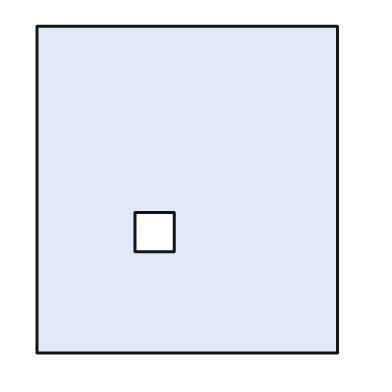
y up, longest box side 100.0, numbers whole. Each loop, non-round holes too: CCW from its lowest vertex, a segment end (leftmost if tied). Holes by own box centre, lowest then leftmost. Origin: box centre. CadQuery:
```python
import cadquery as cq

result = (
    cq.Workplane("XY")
    .moveTo(-46.0, -50.0)
    .lineTo(46.0, -50.0)
    .lineTo(46.0, 50.0)
    .lineTo(-46.0, 50.0)
    .close()
    .moveTo(-16.0, -19.0)
    .lineTo(-4.0, -19.0)
    .lineTo(-4.0, -7.0)
    .lineTo(-16.0, -7.0)
    .close()
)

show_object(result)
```